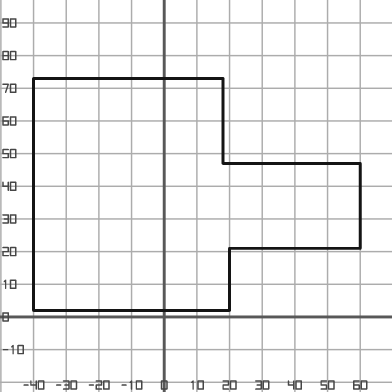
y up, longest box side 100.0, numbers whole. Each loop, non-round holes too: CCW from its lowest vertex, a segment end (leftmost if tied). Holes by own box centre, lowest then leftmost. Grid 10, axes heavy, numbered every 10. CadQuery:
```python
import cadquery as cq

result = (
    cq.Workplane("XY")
    .moveTo(-40.0, 2.0)
    .lineTo(20.0, 2.0)
    .lineTo(20.0, 21.0)
    .lineTo(60.0, 21.0)
    .lineTo(60.0, 47.0)
    .lineTo(18.0, 47.0)
    .lineTo(18.0, 73.0)
    .lineTo(-40.0, 73.0)
    .close()
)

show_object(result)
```